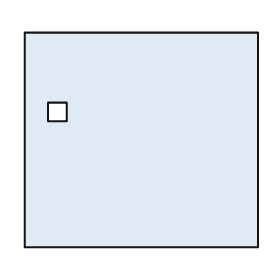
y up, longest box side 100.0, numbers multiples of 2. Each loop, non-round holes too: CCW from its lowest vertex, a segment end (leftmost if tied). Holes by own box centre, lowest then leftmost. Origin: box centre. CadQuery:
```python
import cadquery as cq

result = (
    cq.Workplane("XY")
    .moveTo(-50.0, -46.0)
    .lineTo(50.0, -46.0)
    .lineTo(50.0, 46.0)
    .lineTo(-50.0, 46.0)
    .close()
    .moveTo(-40.0, 8.0)
    .lineTo(-32.0, 8.0)
    .lineTo(-32.0, 16.0)
    .lineTo(-40.0, 16.0)
    .close()
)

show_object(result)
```